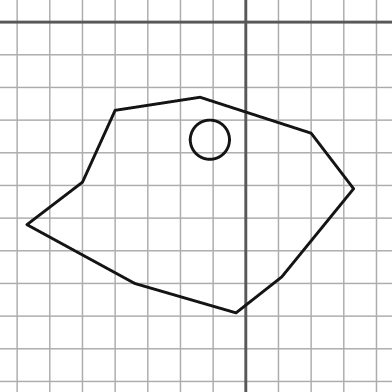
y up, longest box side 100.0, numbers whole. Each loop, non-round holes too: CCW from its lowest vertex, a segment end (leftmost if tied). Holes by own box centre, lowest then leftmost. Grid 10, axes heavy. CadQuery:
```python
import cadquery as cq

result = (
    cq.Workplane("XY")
    .moveTo(-3.0, -89.0)
    .lineTo(11.0, -78.0)
    .lineTo(33.0, -51.0)
    .lineTo(20.0, -34.0)
    .lineTo(-14.0, -23.0)
    .lineTo(-40.0, -27.0)
    .lineTo(-50.0, -49.0)
    .lineTo(-67.0, -62.0)
    .lineTo(-34.0, -80.0)
    .close()
    .moveTo(-11.0, -36.0)
    .circle(6.0)
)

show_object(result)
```